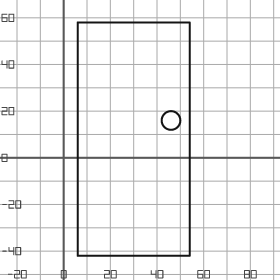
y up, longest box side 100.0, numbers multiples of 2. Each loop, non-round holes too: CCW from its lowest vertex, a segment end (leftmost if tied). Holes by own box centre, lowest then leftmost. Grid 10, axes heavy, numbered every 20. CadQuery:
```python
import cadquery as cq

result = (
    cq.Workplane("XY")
    .moveTo(6.0, -42.0)
    .lineTo(54.0, -42.0)
    .lineTo(54.0, 58.0)
    .lineTo(6.0, 58.0)
    .close()
    .moveTo(46.0, 16.0)
    .circle(4.0)
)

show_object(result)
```